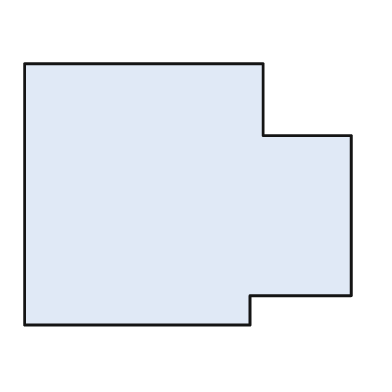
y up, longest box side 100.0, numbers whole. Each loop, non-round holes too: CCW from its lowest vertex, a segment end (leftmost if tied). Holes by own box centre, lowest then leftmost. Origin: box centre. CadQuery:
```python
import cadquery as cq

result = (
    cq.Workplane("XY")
    .moveTo(-50.0, -40.0)
    .lineTo(19.0, -40.0)
    .lineTo(19.0, -31.0)
    .lineTo(50.0, -31.0)
    .lineTo(50.0, 18.0)
    .lineTo(23.0, 18.0)
    .lineTo(23.0, 40.0)
    .lineTo(-50.0, 40.0)
    .close()
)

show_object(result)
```